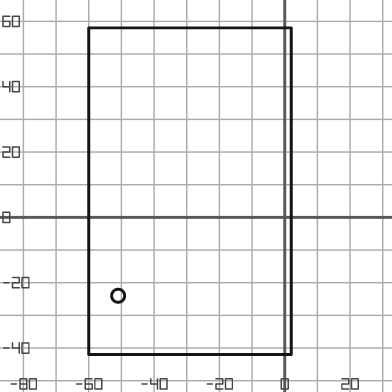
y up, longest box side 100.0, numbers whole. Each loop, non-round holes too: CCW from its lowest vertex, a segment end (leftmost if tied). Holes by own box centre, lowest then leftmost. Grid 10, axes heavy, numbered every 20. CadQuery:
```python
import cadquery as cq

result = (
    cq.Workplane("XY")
    .moveTo(-60.0, -42.0)
    .lineTo(2.0, -42.0)
    .lineTo(2.0, 58.0)
    .lineTo(-60.0, 58.0)
    .close()
    .moveTo(-51.0, -24.0)
    .circle(2.0)
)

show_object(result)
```